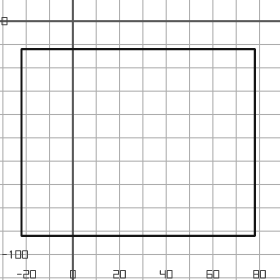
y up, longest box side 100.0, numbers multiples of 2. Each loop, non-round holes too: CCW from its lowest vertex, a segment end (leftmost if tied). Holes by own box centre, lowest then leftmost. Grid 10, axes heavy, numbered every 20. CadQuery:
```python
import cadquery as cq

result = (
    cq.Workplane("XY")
    .moveTo(-22.0, -92.0)
    .lineTo(78.0, -92.0)
    .lineTo(78.0, -12.0)
    .lineTo(-22.0, -12.0)
    .close()
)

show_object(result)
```